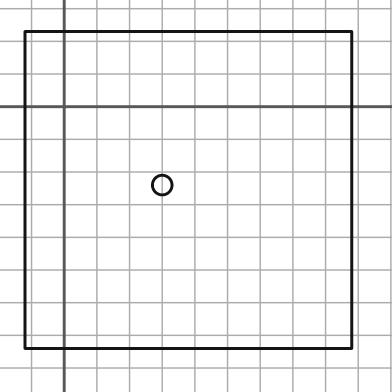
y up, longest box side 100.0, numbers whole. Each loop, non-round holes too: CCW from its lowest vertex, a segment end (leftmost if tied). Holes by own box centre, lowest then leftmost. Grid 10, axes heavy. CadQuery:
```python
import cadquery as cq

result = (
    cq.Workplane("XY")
    .moveTo(-12.0, -74.0)
    .lineTo(88.0, -74.0)
    .lineTo(88.0, 23.0)
    .lineTo(-12.0, 23.0)
    .close()
    .moveTo(30.0, -24.0)
    .circle(3.0)
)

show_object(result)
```